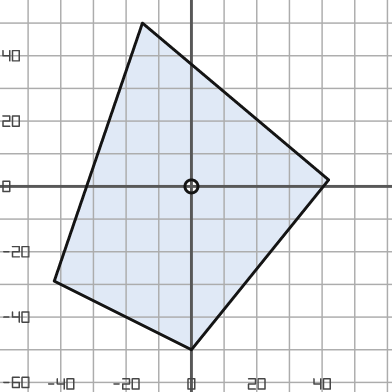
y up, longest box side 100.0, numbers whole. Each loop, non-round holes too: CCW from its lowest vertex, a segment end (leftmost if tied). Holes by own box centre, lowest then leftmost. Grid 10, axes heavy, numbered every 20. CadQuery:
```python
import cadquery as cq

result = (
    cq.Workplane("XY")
    .moveTo(0.0, -50.0)
    .lineTo(42.0, 2.0)
    .lineTo(-15.0, 50.0)
    .lineTo(-42.0, -29.0)
    .close()
    .moveTo(0.0, 0.0)
    .circle(2.0)
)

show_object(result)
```